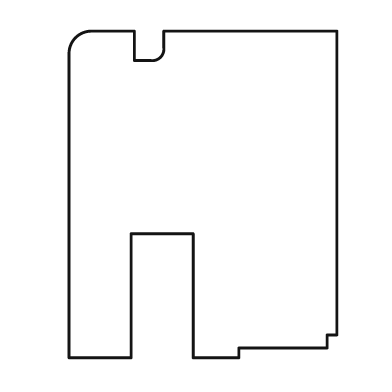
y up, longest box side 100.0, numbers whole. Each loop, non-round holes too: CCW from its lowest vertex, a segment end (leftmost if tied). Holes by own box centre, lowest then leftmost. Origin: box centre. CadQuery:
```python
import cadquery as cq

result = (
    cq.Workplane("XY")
    .moveTo(-41.0, -50.0)
    .lineTo(-22.0, -50.0)
    .lineTo(-22.0, -12.0)
    .lineTo(-3.0, -12.0)
    .lineTo(-3.0, -50.0)
    .lineTo(11.0, -50.0)
    .lineTo(11.0, -47.0)
    .lineTo(38.0, -47.0)
    .lineTo(38.0, -43.0)
    .lineTo(41.0, -43.0)
    .lineTo(41.0, 50.0)
    .lineTo(-12.0, 50.0)
    .lineTo(-12.0, 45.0)
    .threePointArc((-13.0, 42.0), (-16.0, 41.0))
    .lineTo(-21.0, 41.0)
    .lineTo(-21.0, 50.0)
    .lineTo(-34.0, 50.0)
    .threePointArc((-39.0, 48.0), (-41.0, 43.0))
    .close()
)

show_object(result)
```